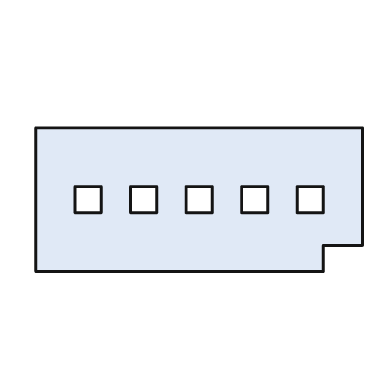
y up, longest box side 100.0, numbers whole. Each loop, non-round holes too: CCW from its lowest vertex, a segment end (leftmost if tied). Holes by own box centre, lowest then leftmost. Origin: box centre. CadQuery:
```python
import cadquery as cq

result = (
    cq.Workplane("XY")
    .moveTo(-50.0, -22.0)
    .lineTo(38.0, -22.0)
    .lineTo(38.0, -14.0)
    .lineTo(50.0, -14.0)
    .lineTo(50.0, 22.0)
    .lineTo(-50.0, 22.0)
    .close()
    .moveTo(-38.0, -4.0)
    .lineTo(-30.0, -4.0)
    .lineTo(-30.0, 4.0)
    .lineTo(-38.0, 4.0)
    .close()
    .moveTo(-21.0, -4.0)
    .lineTo(-13.0, -4.0)
    .lineTo(-13.0, 4.0)
    .lineTo(-21.0, 4.0)
    .close()
    .moveTo(-4.0, -4.0)
    .lineTo(4.0, -4.0)
    .lineTo(4.0, 4.0)
    .lineTo(-4.0, 4.0)
    .close()
    .moveTo(13.0, -4.0)
    .lineTo(21.0, -4.0)
    .lineTo(21.0, 4.0)
    .lineTo(13.0, 4.0)
    .close()
    .moveTo(30.0, -4.0)
    .lineTo(38.0, -4.0)
    .lineTo(38.0, 4.0)
    .lineTo(30.0, 4.0)
    .close()
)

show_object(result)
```